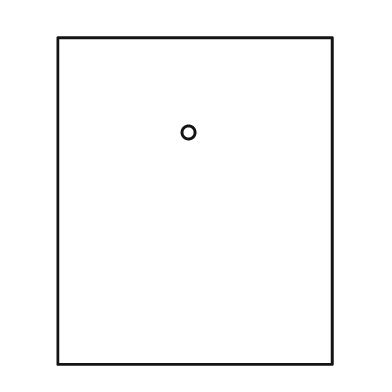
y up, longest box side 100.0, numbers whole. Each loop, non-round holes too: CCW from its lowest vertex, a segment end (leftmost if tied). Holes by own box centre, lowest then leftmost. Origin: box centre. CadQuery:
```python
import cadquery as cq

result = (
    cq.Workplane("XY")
    .moveTo(-42.0, -50.0)
    .lineTo(42.0, -50.0)
    .lineTo(42.0, 50.0)
    .lineTo(-42.0, 50.0)
    .close()
    .moveTo(-2.0, 21.0)
    .circle(2.0)
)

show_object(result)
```